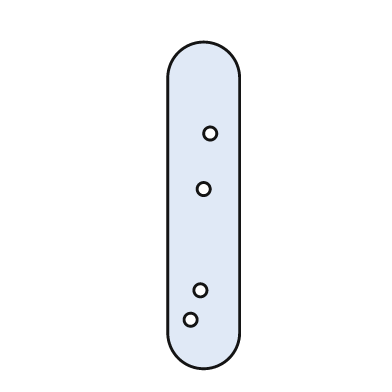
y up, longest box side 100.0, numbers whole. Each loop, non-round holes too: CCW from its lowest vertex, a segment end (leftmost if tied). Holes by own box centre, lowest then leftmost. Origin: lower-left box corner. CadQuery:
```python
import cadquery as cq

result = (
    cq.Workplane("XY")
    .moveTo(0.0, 11.0)
    .threePointArc((11.0, 0.0), (22.0, 11.0))
    .lineTo(22.0, 89.0)
    .threePointArc((11.0, 100.0), (0.0, 89.0))
    .close()
    .moveTo(7.0, 15.0)
    .circle(2.0)
    .moveTo(10.0, 24.0)
    .circle(2.0)
    .moveTo(11.0, 55.0)
    .circle(2.0)
    .moveTo(13.0, 72.0)
    .circle(2.0)
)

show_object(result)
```